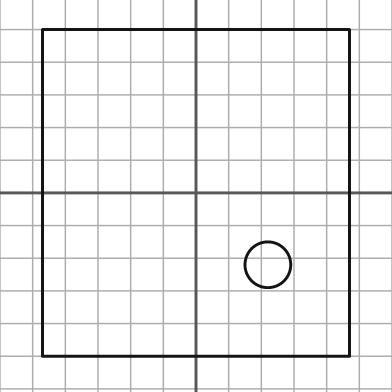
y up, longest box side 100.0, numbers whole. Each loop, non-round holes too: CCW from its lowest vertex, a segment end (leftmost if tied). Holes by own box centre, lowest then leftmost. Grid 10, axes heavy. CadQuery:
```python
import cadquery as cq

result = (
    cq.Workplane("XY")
    .moveTo(-47.0, -50.0)
    .lineTo(47.0, -50.0)
    .lineTo(47.0, 50.0)
    .lineTo(-47.0, 50.0)
    .close()
    .moveTo(22.0, -22.0)
    .circle(7.0)
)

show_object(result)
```